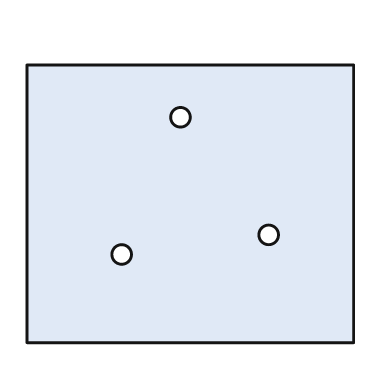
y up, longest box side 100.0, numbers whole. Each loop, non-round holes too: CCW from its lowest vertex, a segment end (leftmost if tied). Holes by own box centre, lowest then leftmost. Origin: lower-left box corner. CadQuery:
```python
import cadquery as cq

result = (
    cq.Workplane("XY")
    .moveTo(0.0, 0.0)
    .lineTo(100.0, 0.0)
    .lineTo(100.0, 85.0)
    .lineTo(0.0, 85.0)
    .close()
    .moveTo(29.0, 27.0)
    .circle(3.0)
    .moveTo(74.0, 33.0)
    .circle(3.0)
    .moveTo(47.0, 69.0)
    .circle(3.0)
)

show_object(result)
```